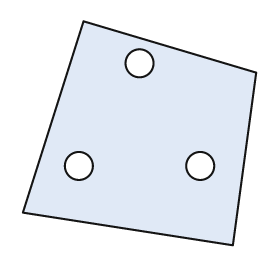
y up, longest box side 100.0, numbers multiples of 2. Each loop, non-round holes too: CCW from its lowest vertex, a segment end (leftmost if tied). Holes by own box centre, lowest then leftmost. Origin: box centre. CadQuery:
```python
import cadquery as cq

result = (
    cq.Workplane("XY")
    .moveTo(40.0, -48.0)
    .lineTo(50.0, 26.0)
    .lineTo(-24.0, 48.0)
    .lineTo(-50.0, -34.0)
    .close()
    .moveTo(-26.0, -14.0)
    .circle(6.0)
    .moveTo(26.0, -14.0)
    .circle(6.0)
    .moveTo(0.0, 30.0)
    .circle(6.0)
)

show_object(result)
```